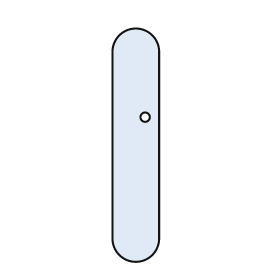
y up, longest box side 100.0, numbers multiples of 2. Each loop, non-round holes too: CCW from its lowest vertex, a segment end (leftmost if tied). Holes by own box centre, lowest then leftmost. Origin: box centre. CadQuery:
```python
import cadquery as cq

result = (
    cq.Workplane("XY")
    .moveTo(-10.0, -40.0)
    .threePointArc((0.0, -50.0), (10.0, -40.0))
    .lineTo(10.0, 40.0)
    .threePointArc((0.0, 50.0), (-10.0, 40.0))
    .close()
    .moveTo(4.0, 12.0)
    .circle(2.0)
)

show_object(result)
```